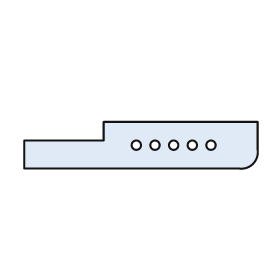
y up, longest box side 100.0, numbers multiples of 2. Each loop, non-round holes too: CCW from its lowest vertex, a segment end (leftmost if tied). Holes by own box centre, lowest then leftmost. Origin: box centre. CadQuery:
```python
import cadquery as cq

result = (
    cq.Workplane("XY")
    .moveTo(-50.0, -10.0)
    .lineTo(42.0, -10.0)
    .threePointArc((48.0, -8.0), (50.0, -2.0))
    .lineTo(50.0, 10.0)
    .lineTo(-16.0, 10.0)
    .lineTo(-16.0, 2.0)
    .lineTo(-50.0, 2.0)
    .close()
    .moveTo(-2.0, 0.0)
    .circle(2.0)
    .moveTo(6.0, 0.0)
    .circle(2.0)
    .moveTo(14.0, 0.0)
    .circle(2.0)
    .moveTo(22.0, 0.0)
    .circle(2.0)
    .moveTo(30.0, 0.0)
    .circle(2.0)
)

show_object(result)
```